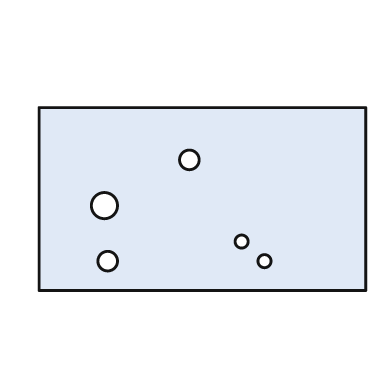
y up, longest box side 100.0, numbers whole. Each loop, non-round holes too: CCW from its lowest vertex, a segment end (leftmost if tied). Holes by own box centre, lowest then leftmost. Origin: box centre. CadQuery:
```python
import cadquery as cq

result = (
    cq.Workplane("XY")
    .moveTo(-50.0, -28.0)
    .lineTo(50.0, -28.0)
    .lineTo(50.0, 28.0)
    .lineTo(-50.0, 28.0)
    .close()
    .moveTo(-29.0, -19.0)
    .circle(3.0)
    .moveTo(19.0, -19.0)
    .circle(2.0)
    .moveTo(12.0, -13.0)
    .circle(2.0)
    .moveTo(-30.0, -2.0)
    .circle(4.0)
    .moveTo(-4.0, 12.0)
    .circle(3.0)
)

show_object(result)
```